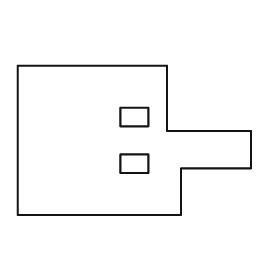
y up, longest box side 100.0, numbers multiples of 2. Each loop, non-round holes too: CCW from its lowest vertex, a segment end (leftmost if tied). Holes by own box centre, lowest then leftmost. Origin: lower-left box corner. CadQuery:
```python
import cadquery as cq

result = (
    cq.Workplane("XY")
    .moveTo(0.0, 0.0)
    .lineTo(70.0, 0.0)
    .lineTo(70.0, 20.0)
    .lineTo(100.0, 20.0)
    .lineTo(100.0, 36.0)
    .lineTo(64.0, 36.0)
    .lineTo(64.0, 64.0)
    .lineTo(0.0, 64.0)
    .close()
    .moveTo(44.0, 18.0)
    .lineTo(56.0, 18.0)
    .lineTo(56.0, 26.0)
    .lineTo(44.0, 26.0)
    .close()
    .moveTo(44.0, 38.0)
    .lineTo(56.0, 38.0)
    .lineTo(56.0, 46.0)
    .lineTo(44.0, 46.0)
    .close()
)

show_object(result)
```